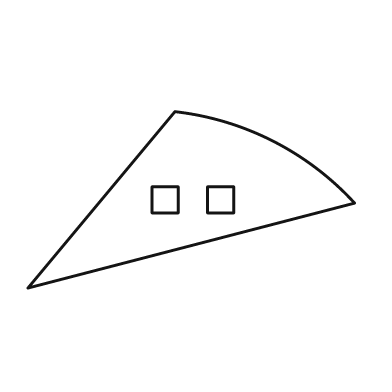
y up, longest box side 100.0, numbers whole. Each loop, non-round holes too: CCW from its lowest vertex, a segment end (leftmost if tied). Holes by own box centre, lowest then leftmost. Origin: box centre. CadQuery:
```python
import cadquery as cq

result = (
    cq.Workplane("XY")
    .moveTo(-50.0, -27.0)
    .lineTo(50.0, -1.0)
    .threePointArc((25.0, 18.0), (-5.0, 27.0))
    .close()
    .moveTo(-12.0, -4.0)
    .lineTo(-4.0, -4.0)
    .lineTo(-4.0, 4.0)
    .lineTo(-12.0, 4.0)
    .close()
    .moveTo(5.0, -4.0)
    .lineTo(13.0, -4.0)
    .lineTo(13.0, 4.0)
    .lineTo(5.0, 4.0)
    .close()
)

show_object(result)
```